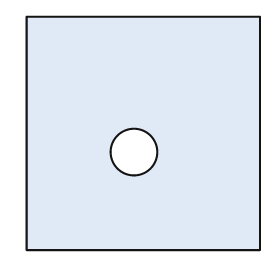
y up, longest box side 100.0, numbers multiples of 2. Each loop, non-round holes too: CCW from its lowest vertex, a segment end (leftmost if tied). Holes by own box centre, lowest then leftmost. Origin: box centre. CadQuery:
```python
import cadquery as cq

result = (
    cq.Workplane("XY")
    .moveTo(-50.0, -50.0)
    .lineTo(50.0, -50.0)
    .lineTo(50.0, 50.0)
    .lineTo(-50.0, 50.0)
    .close()
    .moveTo(-4.0, -8.0)
    .circle(10.0)
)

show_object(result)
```